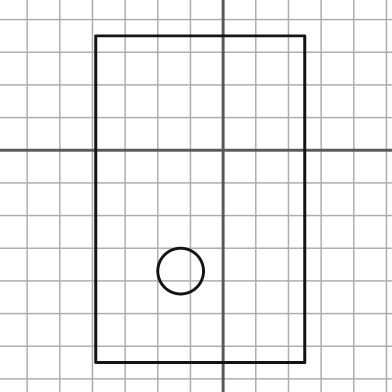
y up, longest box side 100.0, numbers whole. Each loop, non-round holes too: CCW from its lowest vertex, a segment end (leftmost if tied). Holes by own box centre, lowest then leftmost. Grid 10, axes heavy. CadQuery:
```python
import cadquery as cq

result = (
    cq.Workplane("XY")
    .moveTo(-39.0, -65.0)
    .lineTo(25.0, -65.0)
    .lineTo(25.0, 35.0)
    .lineTo(-39.0, 35.0)
    .close()
    .moveTo(-13.0, -37.0)
    .circle(7.0)
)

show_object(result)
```